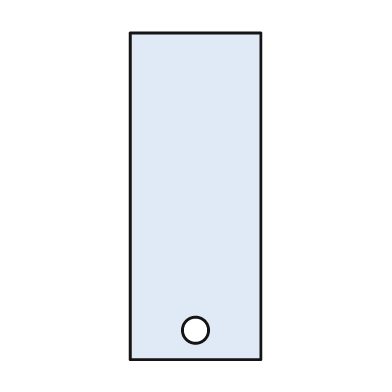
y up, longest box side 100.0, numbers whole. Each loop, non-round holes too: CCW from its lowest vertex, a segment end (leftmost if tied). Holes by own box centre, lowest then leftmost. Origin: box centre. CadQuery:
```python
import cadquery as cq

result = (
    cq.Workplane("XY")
    .moveTo(-20.0, -50.0)
    .lineTo(20.0, -50.0)
    .lineTo(20.0, 50.0)
    .lineTo(-20.0, 50.0)
    .close()
    .moveTo(0.0, -41.0)
    .circle(4.0)
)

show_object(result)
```